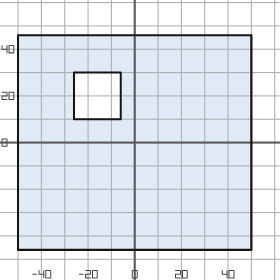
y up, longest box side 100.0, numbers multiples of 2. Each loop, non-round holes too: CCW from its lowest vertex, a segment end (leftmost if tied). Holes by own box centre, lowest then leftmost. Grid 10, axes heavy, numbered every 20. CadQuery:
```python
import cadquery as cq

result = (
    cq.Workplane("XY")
    .moveTo(-50.0, -46.0)
    .lineTo(50.0, -46.0)
    .lineTo(50.0, 46.0)
    .lineTo(-50.0, 46.0)
    .close()
    .moveTo(-26.0, 10.0)
    .lineTo(-6.0, 10.0)
    .lineTo(-6.0, 30.0)
    .lineTo(-26.0, 30.0)
    .close()
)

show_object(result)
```